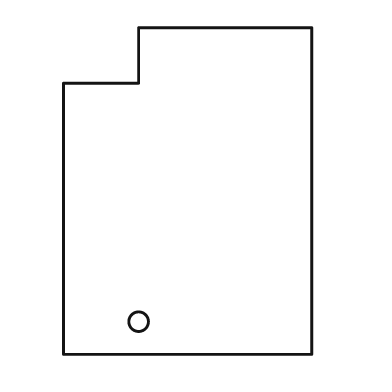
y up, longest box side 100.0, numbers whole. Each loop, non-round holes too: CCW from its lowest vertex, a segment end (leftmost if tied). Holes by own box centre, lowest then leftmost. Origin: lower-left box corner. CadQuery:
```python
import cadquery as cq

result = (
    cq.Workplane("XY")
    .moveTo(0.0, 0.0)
    .lineTo(76.0, 0.0)
    .lineTo(76.0, 100.0)
    .lineTo(23.0, 100.0)
    .lineTo(23.0, 83.0)
    .lineTo(0.0, 83.0)
    .close()
    .moveTo(23.0, 10.0)
    .circle(3.0)
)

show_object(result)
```